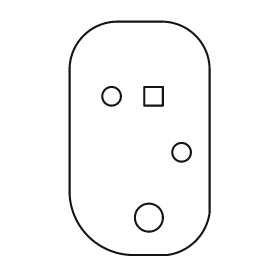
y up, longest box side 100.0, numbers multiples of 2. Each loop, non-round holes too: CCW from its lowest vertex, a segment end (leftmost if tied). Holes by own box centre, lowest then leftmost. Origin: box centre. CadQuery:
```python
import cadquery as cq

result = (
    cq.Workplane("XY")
    .moveTo(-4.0, -50.0)
    .lineTo(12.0, -50.0)
    .threePointArc((24.0, -44.0), (30.0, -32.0))
    .lineTo(30.0, 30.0)
    .threePointArc((24.0, 44.0), (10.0, 50.0))
    .lineTo(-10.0, 50.0)
    .threePointArc((-24.0, 44.0), (-30.0, 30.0))
    .lineTo(-30.0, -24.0)
    .threePointArc((-22.0, -42.0), (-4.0, -50.0))
    .close()
    .moveTo(4.0, -34.0)
    .circle(6.0)
    .moveTo(18.0, -6.0)
    .circle(4.0)
    .moveTo(-12.0, 18.0)
    .circle(4.0)
    .moveTo(2.0, 14.0)
    .lineTo(10.0, 14.0)
    .lineTo(10.0, 22.0)
    .lineTo(2.0, 22.0)
    .close()
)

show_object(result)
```